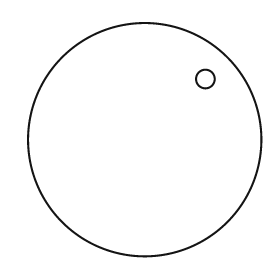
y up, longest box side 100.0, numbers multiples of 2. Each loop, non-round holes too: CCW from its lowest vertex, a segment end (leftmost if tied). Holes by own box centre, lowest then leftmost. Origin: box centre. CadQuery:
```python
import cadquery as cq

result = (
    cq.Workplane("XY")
    .moveTo(0.0, 0.0)
    .circle(50.0)
    .moveTo(26.0, 26.0)
    .circle(4.0)
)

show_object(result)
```